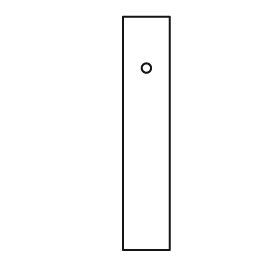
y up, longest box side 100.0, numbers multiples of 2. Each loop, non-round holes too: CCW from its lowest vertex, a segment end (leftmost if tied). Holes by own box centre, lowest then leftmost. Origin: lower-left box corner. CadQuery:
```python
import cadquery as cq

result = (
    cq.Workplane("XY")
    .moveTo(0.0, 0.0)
    .lineTo(20.0, 0.0)
    .lineTo(20.0, 100.0)
    .lineTo(0.0, 100.0)
    .close()
    .moveTo(10.0, 78.0)
    .circle(2.0)
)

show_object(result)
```